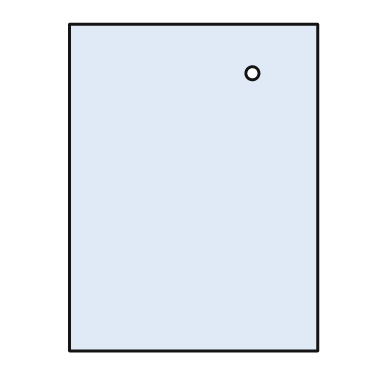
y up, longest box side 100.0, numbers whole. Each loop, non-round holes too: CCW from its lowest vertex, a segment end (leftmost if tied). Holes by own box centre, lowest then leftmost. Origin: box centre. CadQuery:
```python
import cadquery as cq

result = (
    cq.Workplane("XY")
    .moveTo(-38.0, -50.0)
    .lineTo(38.0, -50.0)
    .lineTo(38.0, 50.0)
    .lineTo(-38.0, 50.0)
    .close()
    .moveTo(18.0, 35.0)
    .circle(2.0)
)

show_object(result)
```